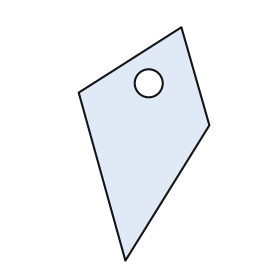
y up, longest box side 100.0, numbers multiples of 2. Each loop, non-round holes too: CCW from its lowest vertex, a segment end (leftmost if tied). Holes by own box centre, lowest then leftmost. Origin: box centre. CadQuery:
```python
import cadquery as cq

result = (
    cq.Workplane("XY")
    .moveTo(-8.0, -50.0)
    .lineTo(28.0, 8.0)
    .lineTo(16.0, 50.0)
    .lineTo(-28.0, 22.0)
    .close()
    .moveTo(2.0, 26.0)
    .circle(6.0)
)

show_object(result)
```